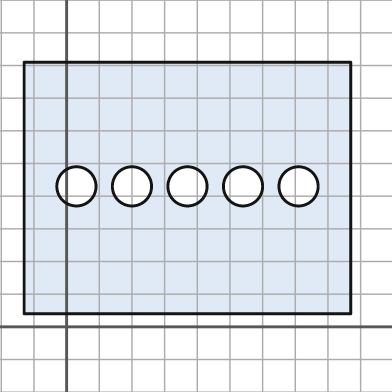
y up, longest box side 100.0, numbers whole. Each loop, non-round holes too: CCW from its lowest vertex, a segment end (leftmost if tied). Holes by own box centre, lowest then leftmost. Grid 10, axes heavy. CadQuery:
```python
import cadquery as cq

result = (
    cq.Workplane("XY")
    .moveTo(-13.0, 4.0)
    .lineTo(87.0, 4.0)
    .lineTo(87.0, 81.0)
    .lineTo(-13.0, 81.0)
    .close()
    .moveTo(3.0, 43.0)
    .circle(6.0)
    .moveTo(20.0, 43.0)
    .circle(6.0)
    .moveTo(37.0, 43.0)
    .circle(6.0)
    .moveTo(54.0, 43.0)
    .circle(6.0)
    .moveTo(71.0, 43.0)
    .circle(6.0)
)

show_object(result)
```